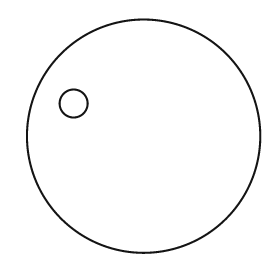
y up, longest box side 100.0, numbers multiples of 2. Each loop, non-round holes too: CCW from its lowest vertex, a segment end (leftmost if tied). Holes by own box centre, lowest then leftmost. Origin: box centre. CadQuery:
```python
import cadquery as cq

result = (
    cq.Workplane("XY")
    .moveTo(0.0, 0.0)
    .circle(50.0)
    .moveTo(-30.0, 14.0)
    .circle(6.0)
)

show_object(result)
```